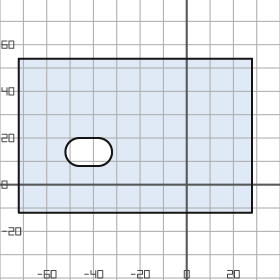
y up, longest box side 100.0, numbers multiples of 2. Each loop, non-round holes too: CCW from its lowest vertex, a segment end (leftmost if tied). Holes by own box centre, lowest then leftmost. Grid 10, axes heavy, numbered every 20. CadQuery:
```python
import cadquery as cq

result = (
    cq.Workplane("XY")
    .moveTo(-72.0, -12.0)
    .lineTo(28.0, -12.0)
    .lineTo(28.0, 54.0)
    .lineTo(-72.0, 54.0)
    .close()
    .moveTo(-46.0, 8.0)
    .lineTo(-38.0, 8.0)
    .threePointArc((-32.0, 14.0), (-38.0, 20.0))
    .lineTo(-46.0, 20.0)
    .threePointArc((-52.0, 14.0), (-46.0, 8.0))
    .close()
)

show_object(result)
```